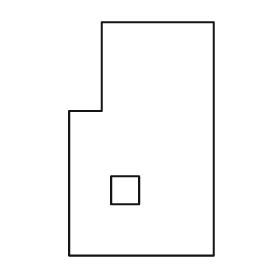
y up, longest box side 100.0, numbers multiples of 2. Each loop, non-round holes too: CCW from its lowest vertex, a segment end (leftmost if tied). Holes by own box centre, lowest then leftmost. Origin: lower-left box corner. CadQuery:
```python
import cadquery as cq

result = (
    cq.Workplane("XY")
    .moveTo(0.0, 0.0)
    .lineTo(62.0, 0.0)
    .lineTo(62.0, 100.0)
    .lineTo(14.0, 100.0)
    .lineTo(14.0, 62.0)
    .lineTo(0.0, 62.0)
    .close()
    .moveTo(18.0, 22.0)
    .lineTo(30.0, 22.0)
    .lineTo(30.0, 34.0)
    .lineTo(18.0, 34.0)
    .close()
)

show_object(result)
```